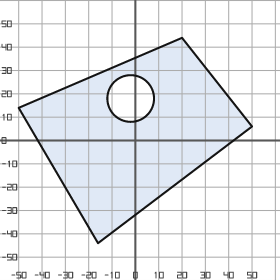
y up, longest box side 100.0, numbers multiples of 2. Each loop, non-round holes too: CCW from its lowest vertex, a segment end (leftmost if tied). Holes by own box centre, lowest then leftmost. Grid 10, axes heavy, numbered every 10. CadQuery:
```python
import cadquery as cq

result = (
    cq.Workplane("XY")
    .moveTo(-16.0, -44.0)
    .lineTo(50.0, 6.0)
    .lineTo(20.0, 44.0)
    .lineTo(-50.0, 14.0)
    .close()
    .moveTo(-2.0, 18.0)
    .circle(10.0)
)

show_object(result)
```